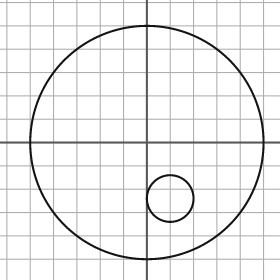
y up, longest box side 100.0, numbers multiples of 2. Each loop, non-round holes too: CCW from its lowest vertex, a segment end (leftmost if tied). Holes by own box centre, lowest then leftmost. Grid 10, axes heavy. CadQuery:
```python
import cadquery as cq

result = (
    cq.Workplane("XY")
    .moveTo(0.0, 0.0)
    .circle(50.0)
    .moveTo(10.0, -24.0)
    .circle(10.0)
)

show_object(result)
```